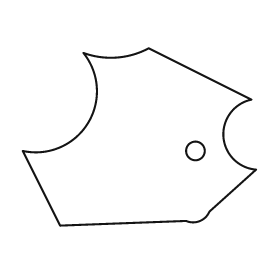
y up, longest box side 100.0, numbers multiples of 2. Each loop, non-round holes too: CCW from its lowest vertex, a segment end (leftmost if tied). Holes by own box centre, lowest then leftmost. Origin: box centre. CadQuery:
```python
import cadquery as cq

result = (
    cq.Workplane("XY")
    .moveTo(-34.0, -38.0)
    .lineTo(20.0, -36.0)
    .threePointArc((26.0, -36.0), (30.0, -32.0))
    .lineTo(50.0, -14.0)
    .threePointArc((36.0, 0.0), (48.0, 16.0))
    .lineTo(4.0, 38.0)
    .threePointArc((-10.0, 34.0), (-24.0, 36.0))
    .threePointArc((-22.0, 6.0), (-50.0, -6.0))
    .close()
    .moveTo(24.0, -6.0)
    .circle(4.0)
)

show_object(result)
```